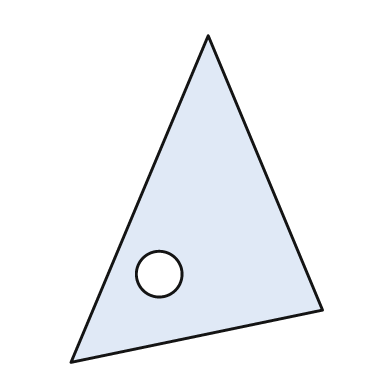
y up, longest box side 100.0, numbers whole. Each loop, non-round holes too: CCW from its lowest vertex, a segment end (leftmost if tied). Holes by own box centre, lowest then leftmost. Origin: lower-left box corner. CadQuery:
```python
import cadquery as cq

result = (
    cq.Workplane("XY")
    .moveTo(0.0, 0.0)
    .lineTo(77.0, 16.0)
    .lineTo(42.0, 100.0)
    .close()
    .moveTo(27.0, 27.0)
    .circle(7.0)
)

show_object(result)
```